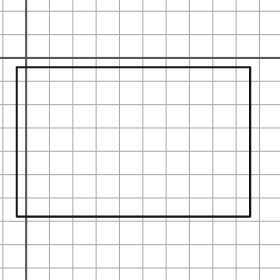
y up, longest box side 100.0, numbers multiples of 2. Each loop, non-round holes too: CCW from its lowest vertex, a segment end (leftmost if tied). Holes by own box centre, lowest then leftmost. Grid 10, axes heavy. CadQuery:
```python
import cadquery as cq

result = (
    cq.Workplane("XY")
    .moveTo(-4.0, -68.0)
    .lineTo(96.0, -68.0)
    .lineTo(96.0, -4.0)
    .lineTo(-4.0, -4.0)
    .close()
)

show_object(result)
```